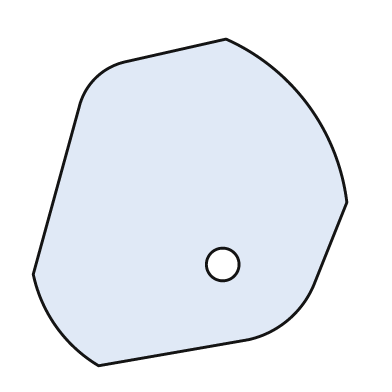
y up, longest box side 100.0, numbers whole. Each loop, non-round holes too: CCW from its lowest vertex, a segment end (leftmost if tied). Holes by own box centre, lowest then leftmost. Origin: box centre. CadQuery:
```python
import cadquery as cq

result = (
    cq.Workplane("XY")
    .moveTo(-28.0, -50.0)
    .lineTo(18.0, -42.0)
    .threePointArc((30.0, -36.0), (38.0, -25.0))
    .lineTo(48.0, 0.0)
    .threePointArc((36.0, 30.0), (11.0, 50.0))
    .lineTo(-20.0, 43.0)
    .threePointArc((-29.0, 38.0), (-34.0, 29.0))
    .lineTo(-48.0, -22.0)
    .threePointArc((-41.0, -38.0), (-28.0, -50.0))
    .close()
    .moveTo(10.0, -19.0)
    .circle(5.0)
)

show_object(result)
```